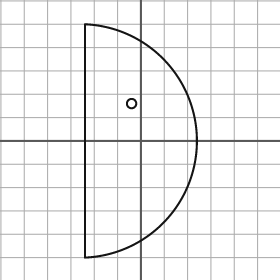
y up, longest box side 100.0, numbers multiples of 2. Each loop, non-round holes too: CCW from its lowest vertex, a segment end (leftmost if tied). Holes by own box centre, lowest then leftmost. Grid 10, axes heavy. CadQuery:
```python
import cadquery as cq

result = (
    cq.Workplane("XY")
    .moveTo(-24.0, -50.0)
    .threePointArc((24.0, 0.0), (-24.0, 50.0))
    .close()
    .moveTo(-4.0, 16.0)
    .circle(2.0)
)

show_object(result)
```